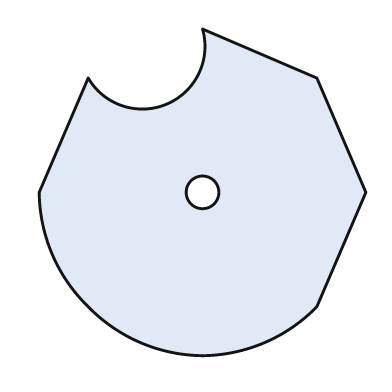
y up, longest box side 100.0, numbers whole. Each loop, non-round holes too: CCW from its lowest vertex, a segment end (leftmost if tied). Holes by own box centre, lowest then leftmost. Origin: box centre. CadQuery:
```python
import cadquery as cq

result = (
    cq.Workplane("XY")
    .moveTo(0.0, -50.0)
    .threePointArc((19.0, -46.0), (35.0, -35.0))
    .lineTo(50.0, 0.0)
    .lineTo(35.0, 35.0)
    .lineTo(0.0, 50.0)
    .threePointArc((-11.0, 27.0), (-35.0, 35.0))
    .lineTo(-50.0, 0.0)
    .threePointArc((-46.0, -19.0), (-35.0, -35.0))
    .threePointArc((-19.0, -46.0), (0.0, -50.0))
    .close()
    .moveTo(0.0, 0.0)
    .circle(5.0)
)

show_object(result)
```